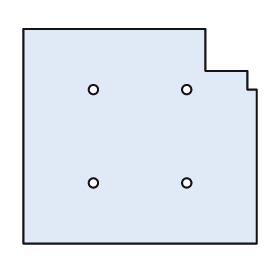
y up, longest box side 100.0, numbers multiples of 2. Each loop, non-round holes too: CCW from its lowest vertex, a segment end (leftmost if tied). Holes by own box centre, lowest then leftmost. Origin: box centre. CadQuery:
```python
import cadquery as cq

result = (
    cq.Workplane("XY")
    .moveTo(-50.0, -46.0)
    .lineTo(50.0, -46.0)
    .lineTo(50.0, 20.0)
    .lineTo(46.0, 20.0)
    .lineTo(46.0, 28.0)
    .lineTo(28.0, 28.0)
    .lineTo(28.0, 46.0)
    .lineTo(-50.0, 46.0)
    .close()
    .moveTo(-20.0, -20.0)
    .circle(2.0)
    .moveTo(20.0, -20.0)
    .circle(2.0)
    .moveTo(-20.0, 20.0)
    .circle(2.0)
    .moveTo(20.0, 20.0)
    .circle(2.0)
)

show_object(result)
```